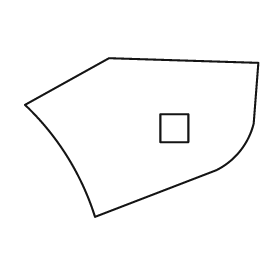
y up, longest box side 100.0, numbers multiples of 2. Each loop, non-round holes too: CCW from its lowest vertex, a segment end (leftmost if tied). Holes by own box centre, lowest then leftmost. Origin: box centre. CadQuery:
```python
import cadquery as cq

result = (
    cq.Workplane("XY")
    .moveTo(-20.0, -34.0)
    .lineTo(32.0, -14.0)
    .threePointArc((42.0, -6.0), (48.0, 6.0))
    .lineTo(50.0, 32.0)
    .lineTo(-14.0, 34.0)
    .lineTo(-50.0, 14.0)
    .threePointArc((-32.0, -8.0), (-20.0, -34.0))
    .close()
    .moveTo(8.0, -2.0)
    .lineTo(20.0, -2.0)
    .lineTo(20.0, 10.0)
    .lineTo(8.0, 10.0)
    .close()
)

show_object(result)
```